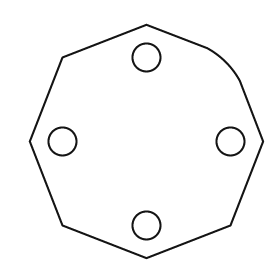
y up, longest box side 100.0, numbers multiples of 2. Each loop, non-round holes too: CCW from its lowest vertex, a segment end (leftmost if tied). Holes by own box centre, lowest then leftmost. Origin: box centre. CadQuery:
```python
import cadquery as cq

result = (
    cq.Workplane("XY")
    .moveTo(0.0, -50.0)
    .lineTo(36.0, -36.0)
    .lineTo(50.0, 0.0)
    .lineTo(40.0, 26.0)
    .threePointArc((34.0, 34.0), (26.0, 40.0))
    .lineTo(0.0, 50.0)
    .lineTo(-36.0, 36.0)
    .lineTo(-50.0, 0.0)
    .lineTo(-36.0, -36.0)
    .close()
    .moveTo(0.0, -36.0)
    .circle(6.0)
    .moveTo(-36.0, 0.0)
    .circle(6.0)
    .moveTo(36.0, 0.0)
    .circle(6.0)
    .moveTo(0.0, 36.0)
    .circle(6.0)
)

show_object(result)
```